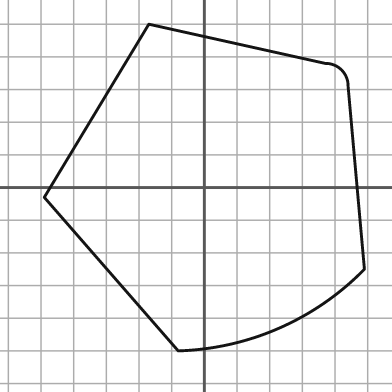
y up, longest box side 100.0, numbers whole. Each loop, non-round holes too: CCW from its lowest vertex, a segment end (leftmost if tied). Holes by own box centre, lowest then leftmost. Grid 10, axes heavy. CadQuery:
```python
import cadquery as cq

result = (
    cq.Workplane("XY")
    .moveTo(-8.0, -50.0)
    .threePointArc((23.0, -43.0), (49.0, -25.0))
    .lineTo(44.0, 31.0)
    .threePointArc((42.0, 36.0), (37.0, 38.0))
    .lineTo(-17.0, 50.0)
    .lineTo(-49.0, -3.0)
    .close()
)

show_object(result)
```